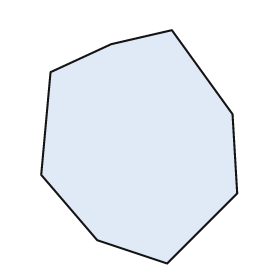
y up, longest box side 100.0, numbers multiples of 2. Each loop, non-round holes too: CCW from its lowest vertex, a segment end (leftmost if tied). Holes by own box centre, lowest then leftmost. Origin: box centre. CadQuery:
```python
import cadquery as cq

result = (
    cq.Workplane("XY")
    .moveTo(12.0, -50.0)
    .lineTo(42.0, -20.0)
    .lineTo(40.0, 14.0)
    .lineTo(14.0, 50.0)
    .lineTo(-12.0, 44.0)
    .lineTo(-38.0, 32.0)
    .lineTo(-42.0, -12.0)
    .lineTo(-18.0, -40.0)
    .close()
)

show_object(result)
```